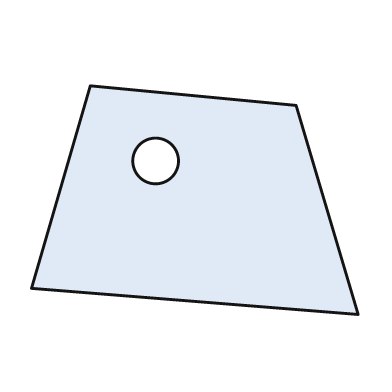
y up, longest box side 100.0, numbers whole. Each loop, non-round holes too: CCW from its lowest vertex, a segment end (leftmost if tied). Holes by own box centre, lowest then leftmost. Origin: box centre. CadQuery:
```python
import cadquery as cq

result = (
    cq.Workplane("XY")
    .moveTo(50.0, -35.0)
    .lineTo(31.0, 29.0)
    .lineTo(-32.0, 35.0)
    .lineTo(-50.0, -27.0)
    .close()
    .moveTo(-12.0, 12.0)
    .circle(7.0)
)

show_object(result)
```